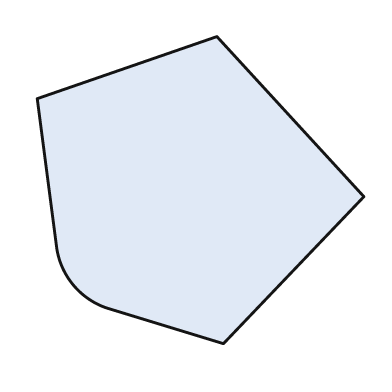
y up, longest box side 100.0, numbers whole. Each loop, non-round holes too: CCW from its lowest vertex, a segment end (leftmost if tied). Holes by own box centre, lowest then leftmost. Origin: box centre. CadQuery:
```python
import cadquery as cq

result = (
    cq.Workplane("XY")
    .moveTo(7.0, -47.0)
    .lineTo(50.0, -2.0)
    .lineTo(5.0, 47.0)
    .lineTo(-50.0, 28.0)
    .lineTo(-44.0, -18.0)
    .threePointArc((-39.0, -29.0), (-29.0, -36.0))
    .close()
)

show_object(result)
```